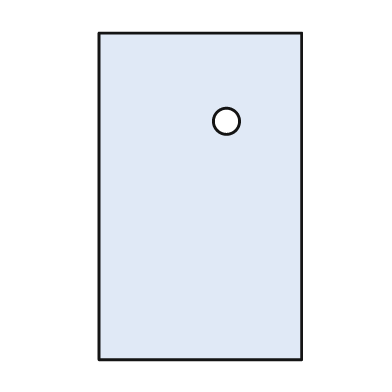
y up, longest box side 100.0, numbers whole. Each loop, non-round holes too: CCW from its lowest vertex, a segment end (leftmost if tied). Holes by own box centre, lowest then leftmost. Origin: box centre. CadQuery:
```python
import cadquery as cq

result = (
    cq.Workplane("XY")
    .moveTo(-31.0, -50.0)
    .lineTo(31.0, -50.0)
    .lineTo(31.0, 50.0)
    .lineTo(-31.0, 50.0)
    .close()
    .moveTo(8.0, 23.0)
    .circle(4.0)
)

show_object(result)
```